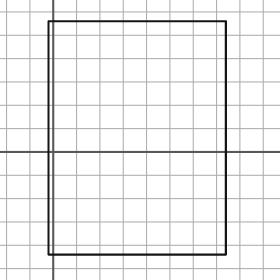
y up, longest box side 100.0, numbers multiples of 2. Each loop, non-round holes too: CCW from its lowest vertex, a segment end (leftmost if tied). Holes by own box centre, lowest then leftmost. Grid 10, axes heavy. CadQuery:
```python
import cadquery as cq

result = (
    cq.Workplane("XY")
    .moveTo(-2.0, -44.0)
    .lineTo(74.0, -44.0)
    .lineTo(74.0, 56.0)
    .lineTo(-2.0, 56.0)
    .close()
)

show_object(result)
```